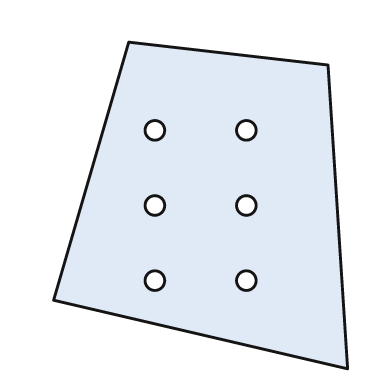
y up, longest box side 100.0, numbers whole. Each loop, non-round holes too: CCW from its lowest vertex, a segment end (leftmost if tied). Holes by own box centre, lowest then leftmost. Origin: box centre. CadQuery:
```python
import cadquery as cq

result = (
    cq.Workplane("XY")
    .moveTo(45.0, -50.0)
    .lineTo(39.0, 43.0)
    .lineTo(-22.0, 50.0)
    .lineTo(-45.0, -29.0)
    .close()
    .moveTo(-14.0, -23.0)
    .circle(3.0)
    .moveTo(14.0, -23.0)
    .circle(3.0)
    .moveTo(-14.0, 0.0)
    .circle(3.0)
    .moveTo(14.0, 0.0)
    .circle(3.0)
    .moveTo(-14.0, 23.0)
    .circle(3.0)
    .moveTo(14.0, 23.0)
    .circle(3.0)
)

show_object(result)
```